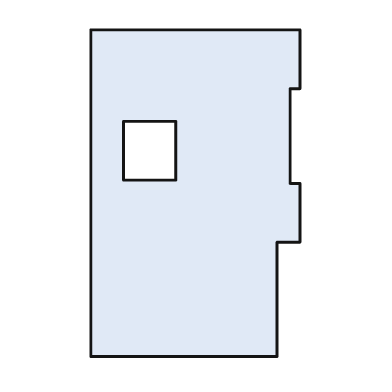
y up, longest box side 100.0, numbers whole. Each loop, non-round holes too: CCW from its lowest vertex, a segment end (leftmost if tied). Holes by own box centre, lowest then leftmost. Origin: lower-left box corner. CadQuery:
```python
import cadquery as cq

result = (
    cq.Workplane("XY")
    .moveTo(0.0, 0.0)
    .lineTo(57.0, 0.0)
    .lineTo(57.0, 35.0)
    .lineTo(64.0, 35.0)
    .lineTo(64.0, 53.0)
    .lineTo(61.0, 53.0)
    .lineTo(61.0, 82.0)
    .lineTo(64.0, 82.0)
    .lineTo(64.0, 100.0)
    .lineTo(0.0, 100.0)
    .close()
    .moveTo(10.0, 54.0)
    .lineTo(26.0, 54.0)
    .lineTo(26.0, 72.0)
    .lineTo(10.0, 72.0)
    .close()
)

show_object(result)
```